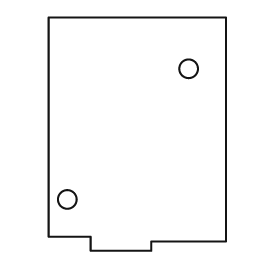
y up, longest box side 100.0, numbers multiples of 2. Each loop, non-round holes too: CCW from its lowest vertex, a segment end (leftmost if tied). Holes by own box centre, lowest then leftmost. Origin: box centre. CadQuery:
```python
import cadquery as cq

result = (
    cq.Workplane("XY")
    .moveTo(-20.0, -50.0)
    .lineTo(6.0, -50.0)
    .lineTo(6.0, -46.0)
    .lineTo(38.0, -46.0)
    .lineTo(38.0, 50.0)
    .lineTo(-38.0, 50.0)
    .lineTo(-38.0, -44.0)
    .lineTo(-20.0, -44.0)
    .close()
    .moveTo(-30.0, -28.0)
    .circle(4.0)
    .moveTo(22.0, 28.0)
    .circle(4.0)
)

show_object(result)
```